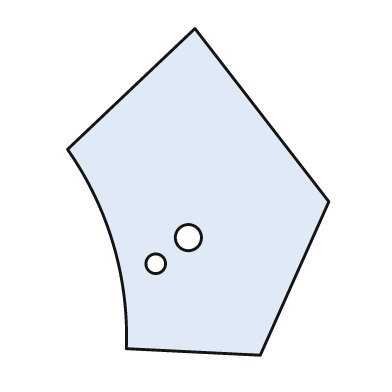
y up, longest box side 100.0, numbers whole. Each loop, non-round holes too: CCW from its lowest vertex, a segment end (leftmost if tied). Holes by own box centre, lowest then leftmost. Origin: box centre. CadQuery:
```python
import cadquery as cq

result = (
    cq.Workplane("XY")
    .moveTo(19.0, -50.0)
    .lineTo(40.0, -3.0)
    .lineTo(-1.0, 50.0)
    .lineTo(-40.0, 13.0)
    .threePointArc((-26.0, -16.0), (-22.0, -48.0))
    .close()
    .moveTo(-13.0, -22.0)
    .circle(3.0)
    .moveTo(-3.0, -14.0)
    .circle(4.0)
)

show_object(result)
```